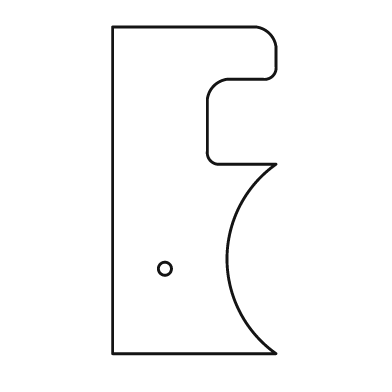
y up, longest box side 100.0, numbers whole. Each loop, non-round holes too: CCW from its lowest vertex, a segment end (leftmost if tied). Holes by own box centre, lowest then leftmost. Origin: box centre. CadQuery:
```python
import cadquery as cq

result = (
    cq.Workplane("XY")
    .moveTo(-25.0, -50.0)
    .lineTo(25.0, -50.0)
    .threePointArc((10.0, -21.0), (25.0, 8.0))
    .lineTo(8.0, 8.0)
    .threePointArc((5.0, 9.0), (4.0, 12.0))
    .lineTo(4.0, 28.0)
    .threePointArc((6.0, 32.0), (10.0, 34.0))
    .lineTo(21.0, 34.0)
    .threePointArc((24.0, 35.0), (25.0, 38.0))
    .lineTo(25.0, 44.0)
    .threePointArc((23.0, 48.0), (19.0, 50.0))
    .lineTo(-25.0, 50.0)
    .close()
    .moveTo(-9.0, -24.0)
    .circle(2.0)
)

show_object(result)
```